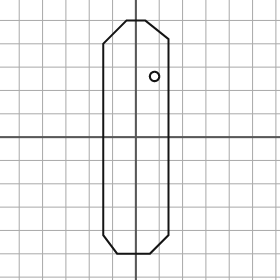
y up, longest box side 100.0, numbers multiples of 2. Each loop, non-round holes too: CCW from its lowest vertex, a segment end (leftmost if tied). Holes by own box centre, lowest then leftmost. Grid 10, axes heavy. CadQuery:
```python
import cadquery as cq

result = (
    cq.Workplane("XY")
    .moveTo(-8.0, -50.0)
    .lineTo(6.0, -50.0)
    .lineTo(14.0, -42.0)
    .lineTo(14.0, 42.0)
    .lineTo(4.0, 50.0)
    .lineTo(-4.0, 50.0)
    .lineTo(-14.0, 40.0)
    .lineTo(-14.0, -42.0)
    .close()
    .moveTo(8.0, 26.0)
    .circle(2.0)
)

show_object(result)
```